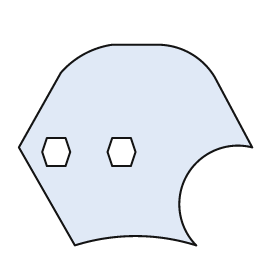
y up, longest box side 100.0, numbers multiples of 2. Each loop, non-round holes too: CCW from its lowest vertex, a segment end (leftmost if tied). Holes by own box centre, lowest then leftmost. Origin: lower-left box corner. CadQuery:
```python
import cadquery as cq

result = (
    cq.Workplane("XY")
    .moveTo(24.0, 0.0)
    .threePointArc((50.0, 4.0), (76.0, 0.0))
    .threePointArc((72.0, 30.0), (100.0, 42.0))
    .lineTo(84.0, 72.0)
    .threePointArc((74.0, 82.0), (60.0, 86.0))
    .lineTo(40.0, 86.0)
    .threePointArc((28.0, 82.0), (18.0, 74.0))
    .lineTo(0.0, 42.0)
    .close()
    .moveTo(12.0, 34.0)
    .lineTo(20.0, 34.0)
    .lineTo(22.0, 40.0)
    .lineTo(20.0, 46.0)
    .lineTo(12.0, 46.0)
    .lineTo(10.0, 40.0)
    .close()
    .moveTo(40.0, 34.0)
    .lineTo(48.0, 34.0)
    .lineTo(50.0, 40.0)
    .lineTo(48.0, 46.0)
    .lineTo(40.0, 46.0)
    .lineTo(38.0, 40.0)
    .close()
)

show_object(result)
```